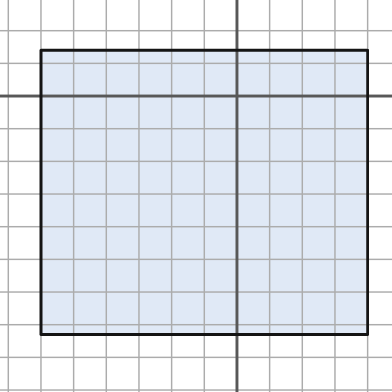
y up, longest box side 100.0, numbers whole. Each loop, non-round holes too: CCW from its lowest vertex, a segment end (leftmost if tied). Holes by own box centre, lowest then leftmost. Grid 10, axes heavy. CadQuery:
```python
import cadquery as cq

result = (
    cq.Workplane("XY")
    .moveTo(-60.0, -73.0)
    .lineTo(40.0, -73.0)
    .lineTo(40.0, 14.0)
    .lineTo(-60.0, 14.0)
    .close()
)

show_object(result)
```